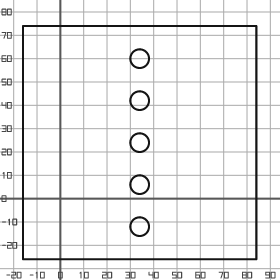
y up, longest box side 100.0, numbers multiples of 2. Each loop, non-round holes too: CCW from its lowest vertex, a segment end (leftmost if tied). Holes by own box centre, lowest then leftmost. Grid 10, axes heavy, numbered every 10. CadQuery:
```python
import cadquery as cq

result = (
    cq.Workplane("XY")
    .moveTo(-16.0, -26.0)
    .lineTo(84.0, -26.0)
    .lineTo(84.0, 74.0)
    .lineTo(-16.0, 74.0)
    .close()
    .moveTo(34.0, -12.0)
    .circle(4.0)
    .moveTo(34.0, 6.0)
    .circle(4.0)
    .moveTo(34.0, 24.0)
    .circle(4.0)
    .moveTo(34.0, 42.0)
    .circle(4.0)
    .moveTo(34.0, 60.0)
    .circle(4.0)
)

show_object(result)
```